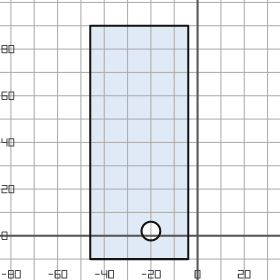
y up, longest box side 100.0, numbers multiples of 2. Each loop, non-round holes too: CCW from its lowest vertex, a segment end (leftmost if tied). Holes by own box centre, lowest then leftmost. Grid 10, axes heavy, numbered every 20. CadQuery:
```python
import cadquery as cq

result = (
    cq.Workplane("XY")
    .moveTo(-46.0, -10.0)
    .lineTo(-4.0, -10.0)
    .lineTo(-4.0, 90.0)
    .lineTo(-46.0, 90.0)
    .close()
    .moveTo(-20.0, 2.0)
    .circle(4.0)
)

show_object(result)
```